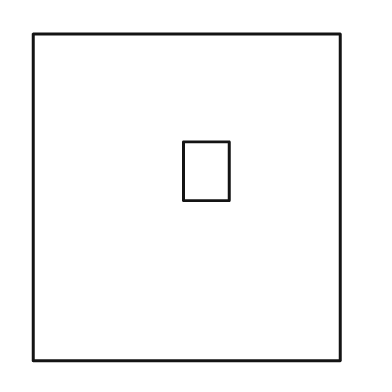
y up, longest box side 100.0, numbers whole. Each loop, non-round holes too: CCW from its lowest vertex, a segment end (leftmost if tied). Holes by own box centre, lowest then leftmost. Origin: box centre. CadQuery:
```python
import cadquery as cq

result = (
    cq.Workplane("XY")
    .moveTo(-47.0, -50.0)
    .lineTo(47.0, -50.0)
    .lineTo(47.0, 50.0)
    .lineTo(-47.0, 50.0)
    .close()
    .moveTo(-1.0, -1.0)
    .lineTo(13.0, -1.0)
    .lineTo(13.0, 17.0)
    .lineTo(-1.0, 17.0)
    .close()
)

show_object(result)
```